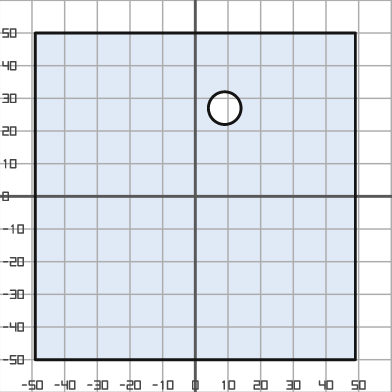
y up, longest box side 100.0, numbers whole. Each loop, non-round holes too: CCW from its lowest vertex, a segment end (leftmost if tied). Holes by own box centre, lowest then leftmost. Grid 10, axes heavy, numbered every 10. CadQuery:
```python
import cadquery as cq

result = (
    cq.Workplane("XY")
    .moveTo(-49.0, -50.0)
    .lineTo(49.0, -50.0)
    .lineTo(49.0, 50.0)
    .lineTo(-49.0, 50.0)
    .close()
    .moveTo(9.0, 27.0)
    .circle(5.0)
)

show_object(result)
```